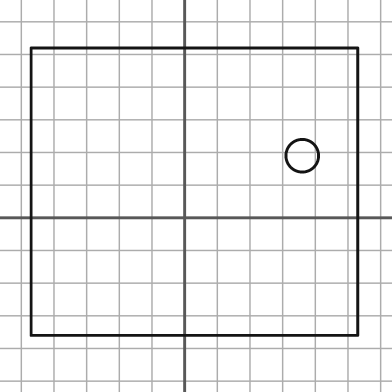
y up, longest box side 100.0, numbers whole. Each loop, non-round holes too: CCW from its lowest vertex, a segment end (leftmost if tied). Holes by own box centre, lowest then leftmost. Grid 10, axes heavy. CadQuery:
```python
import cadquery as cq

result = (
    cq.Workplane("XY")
    .moveTo(-47.0, -36.0)
    .lineTo(53.0, -36.0)
    .lineTo(53.0, 52.0)
    .lineTo(-47.0, 52.0)
    .close()
    .moveTo(36.0, 19.0)
    .circle(5.0)
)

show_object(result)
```